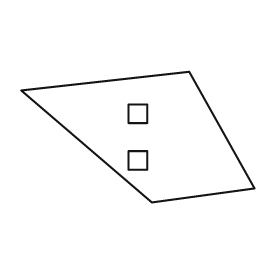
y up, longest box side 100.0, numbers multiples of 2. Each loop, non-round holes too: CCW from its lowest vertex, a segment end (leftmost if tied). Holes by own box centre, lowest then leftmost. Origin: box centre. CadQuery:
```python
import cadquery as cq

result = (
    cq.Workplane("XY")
    .moveTo(6.0, -28.0)
    .lineTo(50.0, -22.0)
    .lineTo(22.0, 28.0)
    .lineTo(-50.0, 20.0)
    .close()
    .moveTo(-4.0, -14.0)
    .lineTo(4.0, -14.0)
    .lineTo(4.0, -6.0)
    .lineTo(-4.0, -6.0)
    .close()
    .moveTo(-4.0, 6.0)
    .lineTo(4.0, 6.0)
    .lineTo(4.0, 14.0)
    .lineTo(-4.0, 14.0)
    .close()
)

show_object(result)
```